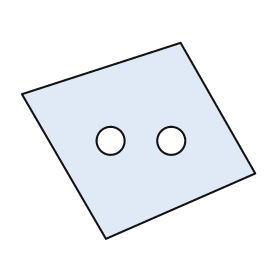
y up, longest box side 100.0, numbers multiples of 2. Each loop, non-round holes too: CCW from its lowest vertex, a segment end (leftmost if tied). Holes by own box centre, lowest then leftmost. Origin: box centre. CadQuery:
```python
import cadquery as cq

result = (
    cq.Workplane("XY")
    .moveTo(-14.0, -42.0)
    .lineTo(50.0, -14.0)
    .lineTo(18.0, 42.0)
    .lineTo(-50.0, 20.0)
    .close()
    .moveTo(-12.0, 0.0)
    .circle(6.0)
    .moveTo(14.0, 0.0)
    .circle(6.0)
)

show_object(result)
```